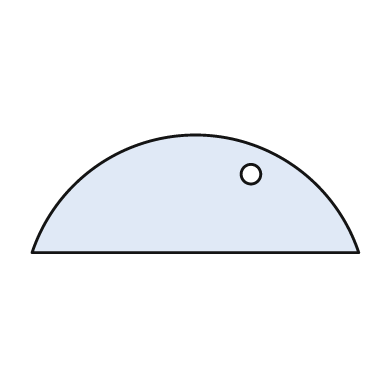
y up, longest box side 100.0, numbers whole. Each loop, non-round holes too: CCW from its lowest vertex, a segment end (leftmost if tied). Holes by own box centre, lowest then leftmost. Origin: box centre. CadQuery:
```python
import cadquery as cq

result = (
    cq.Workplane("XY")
    .moveTo(-50.0, -18.0)
    .lineTo(50.0, -18.0)
    .threePointArc((0.0, 18.0), (-50.0, -18.0))
    .close()
    .moveTo(17.0, 6.0)
    .circle(3.0)
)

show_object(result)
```